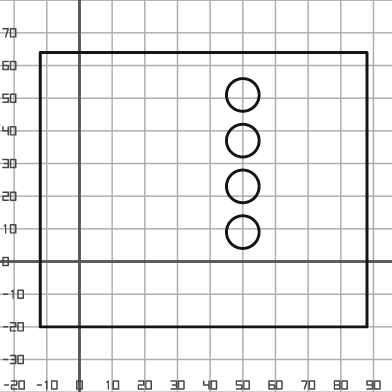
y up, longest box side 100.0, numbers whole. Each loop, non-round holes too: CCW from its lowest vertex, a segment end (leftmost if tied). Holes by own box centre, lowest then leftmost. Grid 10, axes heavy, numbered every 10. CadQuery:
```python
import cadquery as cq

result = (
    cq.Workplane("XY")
    .moveTo(-12.0, -20.0)
    .lineTo(88.0, -20.0)
    .lineTo(88.0, 64.0)
    .lineTo(-12.0, 64.0)
    .close()
    .moveTo(50.0, 9.0)
    .circle(5.0)
    .moveTo(50.0, 23.0)
    .circle(5.0)
    .moveTo(50.0, 37.0)
    .circle(5.0)
    .moveTo(50.0, 51.0)
    .circle(5.0)
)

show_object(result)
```